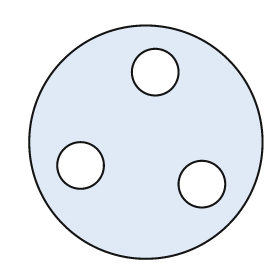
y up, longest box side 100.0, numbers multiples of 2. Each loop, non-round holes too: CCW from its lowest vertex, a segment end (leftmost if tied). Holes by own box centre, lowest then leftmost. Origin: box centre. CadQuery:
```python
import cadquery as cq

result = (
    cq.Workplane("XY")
    .moveTo(0.0, 0.0)
    .circle(50.0)
    .moveTo(24.0, -18.0)
    .circle(10.0)
    .moveTo(-28.0, -10.0)
    .circle(10.0)
    .moveTo(4.0, 30.0)
    .circle(10.0)
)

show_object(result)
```